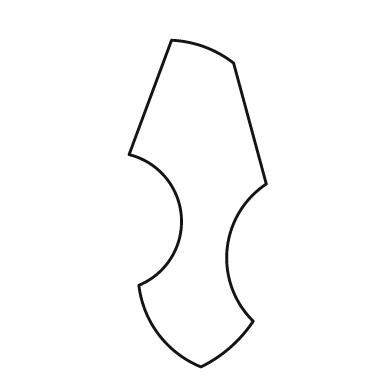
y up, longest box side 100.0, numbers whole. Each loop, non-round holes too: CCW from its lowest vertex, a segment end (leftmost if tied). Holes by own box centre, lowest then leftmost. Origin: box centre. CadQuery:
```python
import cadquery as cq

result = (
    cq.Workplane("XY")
    .moveTo(1.0, -50.0)
    .threePointArc((10.0, -44.0), (17.0, -36.0))
    .threePointArc((9.0, -14.0), (21.0, 6.0))
    .lineTo(11.0, 43.0)
    .threePointArc((2.0, 48.0), (-8.0, 50.0))
    .lineTo(-21.0, 15.0)
    .threePointArc((-5.0, -4.0), (-18.0, -25.0))
    .threePointArc((-12.0, -40.0), (1.0, -50.0))
    .close()
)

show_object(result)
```